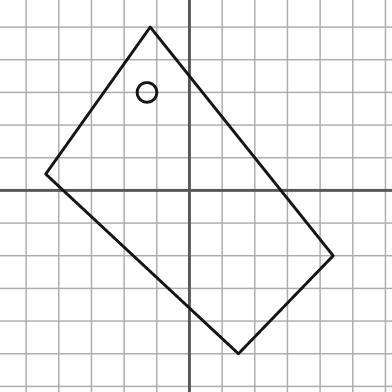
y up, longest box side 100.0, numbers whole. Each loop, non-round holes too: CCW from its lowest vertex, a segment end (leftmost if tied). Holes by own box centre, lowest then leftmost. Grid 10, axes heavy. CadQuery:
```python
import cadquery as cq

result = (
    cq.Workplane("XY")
    .moveTo(15.0, -50.0)
    .lineTo(44.0, -20.0)
    .lineTo(-12.0, 50.0)
    .lineTo(-44.0, 5.0)
    .close()
    .moveTo(-13.0, 30.0)
    .circle(3.0)
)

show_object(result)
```